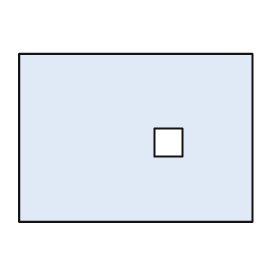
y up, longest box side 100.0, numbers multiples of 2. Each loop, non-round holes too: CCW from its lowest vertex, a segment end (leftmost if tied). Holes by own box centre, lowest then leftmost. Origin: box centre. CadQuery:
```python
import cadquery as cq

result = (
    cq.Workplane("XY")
    .moveTo(-50.0, -36.0)
    .lineTo(50.0, -36.0)
    .lineTo(50.0, 36.0)
    .lineTo(-50.0, 36.0)
    .close()
    .moveTo(8.0, -8.0)
    .lineTo(20.0, -8.0)
    .lineTo(20.0, 4.0)
    .lineTo(8.0, 4.0)
    .close()
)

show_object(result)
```